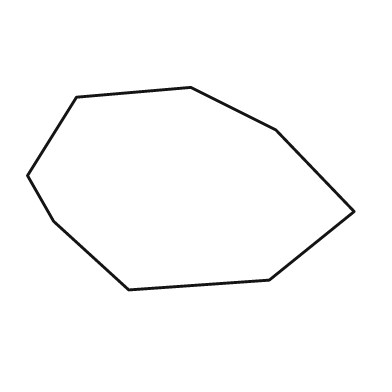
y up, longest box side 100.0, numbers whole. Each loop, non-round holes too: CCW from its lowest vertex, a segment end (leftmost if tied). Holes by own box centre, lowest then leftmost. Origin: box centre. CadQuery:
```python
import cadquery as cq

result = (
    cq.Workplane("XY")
    .moveTo(-19.0, -31.0)
    .lineTo(24.0, -28.0)
    .lineTo(50.0, -7.0)
    .lineTo(26.0, 18.0)
    .lineTo(0.0, 31.0)
    .lineTo(-35.0, 28.0)
    .lineTo(-50.0, 4.0)
    .lineTo(-42.0, -10.0)
    .close()
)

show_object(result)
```